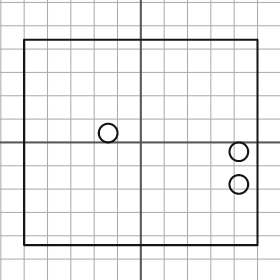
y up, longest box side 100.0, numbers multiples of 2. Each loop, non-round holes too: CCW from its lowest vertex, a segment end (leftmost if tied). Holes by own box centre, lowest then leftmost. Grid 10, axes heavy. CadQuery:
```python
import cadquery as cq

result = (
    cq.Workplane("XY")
    .moveTo(-50.0, -44.0)
    .lineTo(50.0, -44.0)
    .lineTo(50.0, 44.0)
    .lineTo(-50.0, 44.0)
    .close()
    .moveTo(42.0, -18.0)
    .circle(4.0)
    .moveTo(42.0, -4.0)
    .circle(4.0)
    .moveTo(-14.0, 4.0)
    .circle(4.0)
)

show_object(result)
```